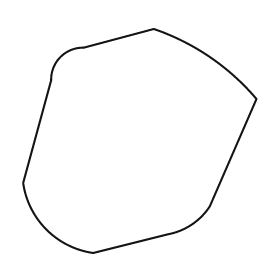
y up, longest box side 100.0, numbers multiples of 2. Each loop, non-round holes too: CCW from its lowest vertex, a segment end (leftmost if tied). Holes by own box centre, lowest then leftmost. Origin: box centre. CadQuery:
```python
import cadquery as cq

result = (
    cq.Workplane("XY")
    .moveTo(-20.0, -48.0)
    .lineTo(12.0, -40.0)
    .threePointArc((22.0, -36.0), (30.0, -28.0))
    .lineTo(50.0, 18.0)
    .threePointArc((30.0, 36.0), (6.0, 48.0))
    .lineTo(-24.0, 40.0)
    .threePointArc((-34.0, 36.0), (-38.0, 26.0))
    .lineTo(-50.0, -18.0)
    .threePointArc((-40.0, -38.0), (-20.0, -48.0))
    .close()
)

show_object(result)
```